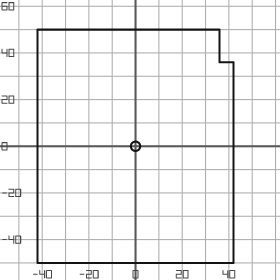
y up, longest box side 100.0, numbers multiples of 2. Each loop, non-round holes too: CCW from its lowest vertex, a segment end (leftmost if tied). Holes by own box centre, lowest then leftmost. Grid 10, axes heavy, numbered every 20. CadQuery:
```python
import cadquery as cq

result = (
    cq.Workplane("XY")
    .moveTo(-42.0, -50.0)
    .lineTo(42.0, -50.0)
    .lineTo(42.0, 36.0)
    .lineTo(36.0, 36.0)
    .lineTo(36.0, 50.0)
    .lineTo(-42.0, 50.0)
    .close()
    .moveTo(0.0, 0.0)
    .circle(2.0)
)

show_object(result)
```